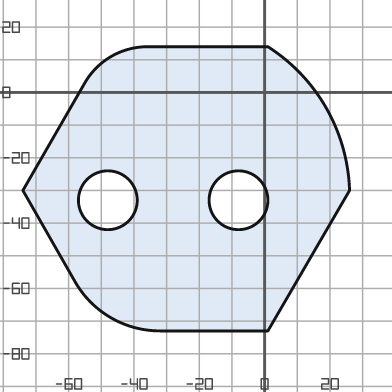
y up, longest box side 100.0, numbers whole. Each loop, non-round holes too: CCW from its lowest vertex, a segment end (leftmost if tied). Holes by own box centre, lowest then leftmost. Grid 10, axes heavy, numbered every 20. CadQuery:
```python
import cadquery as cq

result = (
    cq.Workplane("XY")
    .moveTo(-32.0, -73.0)
    .lineTo(1.0, -73.0)
    .lineTo(26.0, -30.0)
    .threePointArc((19.0, -5.0), (1.0, 14.0))
    .lineTo(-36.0, 14.0)
    .threePointArc((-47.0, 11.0), (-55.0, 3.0))
    .lineTo(-74.0, -30.0)
    .lineTo(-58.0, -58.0)
    .threePointArc((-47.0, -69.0), (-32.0, -73.0))
    .close()
    .moveTo(-48.0, -33.0)
    .circle(9.0)
    .moveTo(-8.0, -33.0)
    .circle(9.0)
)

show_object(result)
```